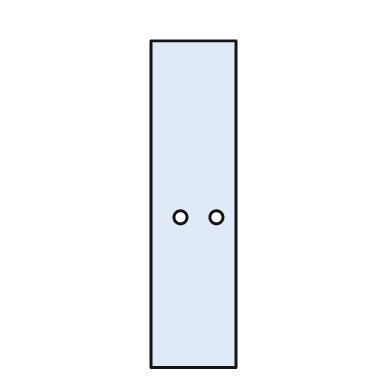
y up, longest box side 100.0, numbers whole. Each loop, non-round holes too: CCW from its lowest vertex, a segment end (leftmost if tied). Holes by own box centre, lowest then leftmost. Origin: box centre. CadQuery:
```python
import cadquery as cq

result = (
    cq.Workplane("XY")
    .moveTo(-13.0, -50.0)
    .lineTo(13.0, -50.0)
    .lineTo(13.0, 50.0)
    .lineTo(-13.0, 50.0)
    .close()
    .moveTo(-4.0, -4.0)
    .circle(2.0)
    .moveTo(7.0, -4.0)
    .circle(2.0)
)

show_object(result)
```